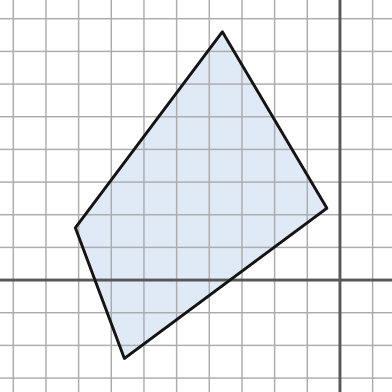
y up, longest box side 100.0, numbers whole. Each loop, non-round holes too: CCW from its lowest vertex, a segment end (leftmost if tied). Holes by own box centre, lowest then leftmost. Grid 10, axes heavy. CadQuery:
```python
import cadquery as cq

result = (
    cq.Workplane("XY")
    .moveTo(-66.0, -24.0)
    .lineTo(-4.0, 22.0)
    .lineTo(-36.0, 76.0)
    .lineTo(-81.0, 16.0)
    .close()
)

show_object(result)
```